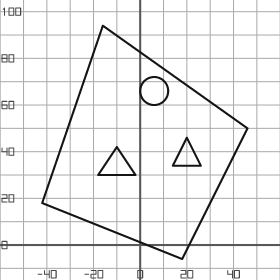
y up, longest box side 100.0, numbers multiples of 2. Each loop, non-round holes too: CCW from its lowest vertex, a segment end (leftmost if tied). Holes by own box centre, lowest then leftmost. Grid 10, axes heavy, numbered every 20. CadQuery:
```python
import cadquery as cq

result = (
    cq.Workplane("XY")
    .moveTo(18.0, -6.0)
    .lineTo(46.0, 50.0)
    .lineTo(-16.0, 94.0)
    .lineTo(-42.0, 18.0)
    .close()
    .moveTo(-18.0, 30.0)
    .lineTo(-2.0, 30.0)
    .lineTo(-10.0, 42.0)
    .close()
    .moveTo(14.0, 34.0)
    .lineTo(26.0, 34.0)
    .lineTo(20.0, 46.0)
    .close()
    .moveTo(6.0, 66.0)
    .circle(6.0)
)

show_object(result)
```